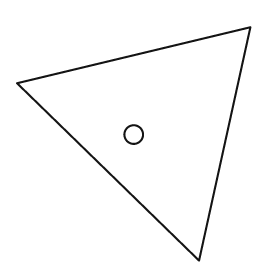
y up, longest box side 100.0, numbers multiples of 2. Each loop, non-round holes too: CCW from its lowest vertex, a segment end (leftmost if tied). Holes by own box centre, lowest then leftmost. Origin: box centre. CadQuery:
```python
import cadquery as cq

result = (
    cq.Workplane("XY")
    .moveTo(28.0, -50.0)
    .lineTo(50.0, 50.0)
    .lineTo(-50.0, 26.0)
    .close()
    .moveTo(0.0, 4.0)
    .circle(4.0)
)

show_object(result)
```